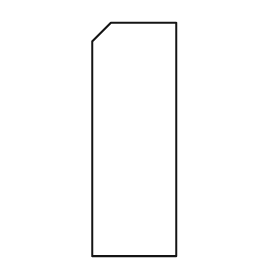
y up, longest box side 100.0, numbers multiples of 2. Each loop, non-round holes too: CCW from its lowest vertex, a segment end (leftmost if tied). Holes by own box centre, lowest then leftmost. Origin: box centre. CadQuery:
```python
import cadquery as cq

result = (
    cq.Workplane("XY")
    .moveTo(-18.0, -50.0)
    .lineTo(18.0, -50.0)
    .lineTo(18.0, 50.0)
    .lineTo(-10.0, 50.0)
    .lineTo(-18.0, 42.0)
    .close()
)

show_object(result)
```